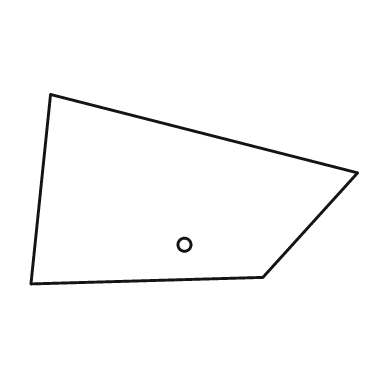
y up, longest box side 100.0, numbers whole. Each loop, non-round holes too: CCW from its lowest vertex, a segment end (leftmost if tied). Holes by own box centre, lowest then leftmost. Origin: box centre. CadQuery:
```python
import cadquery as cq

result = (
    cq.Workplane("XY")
    .moveTo(-50.0, -29.0)
    .lineTo(21.0, -27.0)
    .lineTo(50.0, 5.0)
    .lineTo(-44.0, 29.0)
    .close()
    .moveTo(-3.0, -17.0)
    .circle(2.0)
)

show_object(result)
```